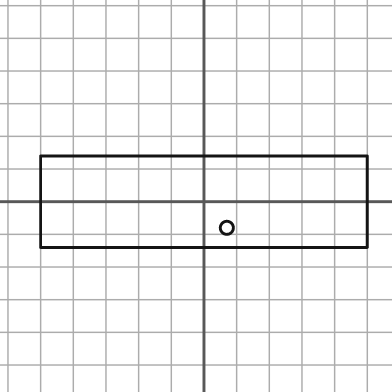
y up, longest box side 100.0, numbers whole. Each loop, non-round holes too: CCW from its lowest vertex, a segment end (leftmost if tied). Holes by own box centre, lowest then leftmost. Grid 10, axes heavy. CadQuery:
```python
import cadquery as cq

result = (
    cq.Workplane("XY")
    .moveTo(-50.0, -14.0)
    .lineTo(50.0, -14.0)
    .lineTo(50.0, 14.0)
    .lineTo(-50.0, 14.0)
    .close()
    .moveTo(7.0, -8.0)
    .circle(2.0)
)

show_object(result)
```